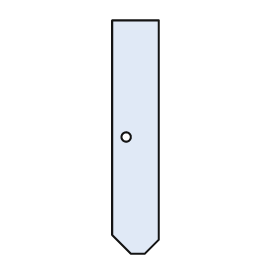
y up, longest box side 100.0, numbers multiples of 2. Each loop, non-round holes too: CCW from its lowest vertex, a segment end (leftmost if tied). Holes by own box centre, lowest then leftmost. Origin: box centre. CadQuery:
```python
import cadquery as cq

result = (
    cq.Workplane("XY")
    .moveTo(-2.0, -50.0)
    .lineTo(4.0, -50.0)
    .lineTo(10.0, -44.0)
    .lineTo(10.0, 50.0)
    .lineTo(-10.0, 50.0)
    .lineTo(-10.0, -42.0)
    .close()
    .moveTo(-4.0, 0.0)
    .circle(2.0)
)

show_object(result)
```